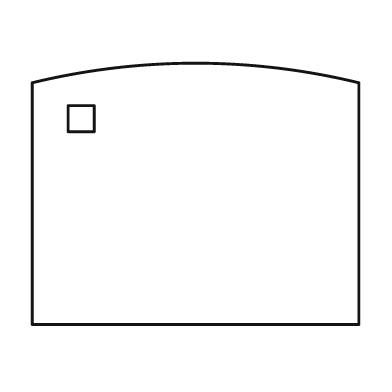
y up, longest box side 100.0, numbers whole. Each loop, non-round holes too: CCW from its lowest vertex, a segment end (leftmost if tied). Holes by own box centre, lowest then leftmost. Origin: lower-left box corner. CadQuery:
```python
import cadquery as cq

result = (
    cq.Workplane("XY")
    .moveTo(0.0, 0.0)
    .lineTo(100.0, 0.0)
    .lineTo(100.0, 74.0)
    .threePointArc((50.0, 80.0), (0.0, 74.0))
    .close()
    .moveTo(11.0, 59.0)
    .lineTo(19.0, 59.0)
    .lineTo(19.0, 67.0)
    .lineTo(11.0, 67.0)
    .close()
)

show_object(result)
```